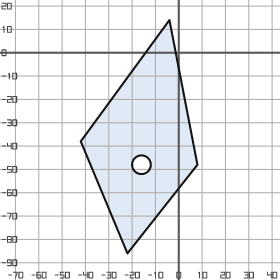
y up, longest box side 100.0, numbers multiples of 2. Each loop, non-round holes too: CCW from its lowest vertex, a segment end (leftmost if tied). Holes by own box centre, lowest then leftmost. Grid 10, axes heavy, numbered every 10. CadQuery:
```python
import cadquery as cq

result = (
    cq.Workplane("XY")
    .moveTo(-22.0, -86.0)
    .lineTo(8.0, -48.0)
    .lineTo(-4.0, 14.0)
    .lineTo(-42.0, -38.0)
    .close()
    .moveTo(-16.0, -48.0)
    .circle(4.0)
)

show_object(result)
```